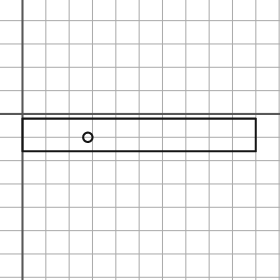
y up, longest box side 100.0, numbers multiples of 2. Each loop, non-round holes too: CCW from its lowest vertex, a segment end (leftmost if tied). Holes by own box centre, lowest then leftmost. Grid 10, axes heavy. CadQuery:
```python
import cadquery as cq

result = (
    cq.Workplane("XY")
    .moveTo(0.0, -16.0)
    .lineTo(100.0, -16.0)
    .lineTo(100.0, -2.0)
    .lineTo(0.0, -2.0)
    .close()
    .moveTo(28.0, -10.0)
    .circle(2.0)
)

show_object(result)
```